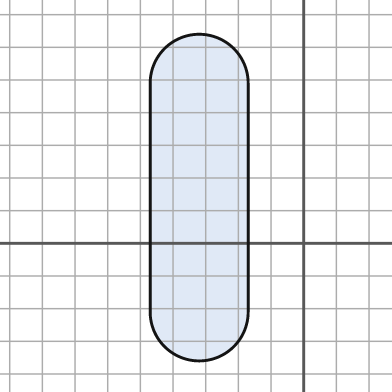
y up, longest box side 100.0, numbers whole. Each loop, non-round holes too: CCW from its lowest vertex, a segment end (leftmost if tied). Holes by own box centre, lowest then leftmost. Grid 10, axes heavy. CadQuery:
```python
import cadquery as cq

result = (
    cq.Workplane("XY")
    .moveTo(-47.0, -21.0)
    .threePointArc((-32.0, -36.0), (-17.0, -21.0))
    .lineTo(-17.0, 49.0)
    .threePointArc((-32.0, 64.0), (-47.0, 49.0))
    .close()
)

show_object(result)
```